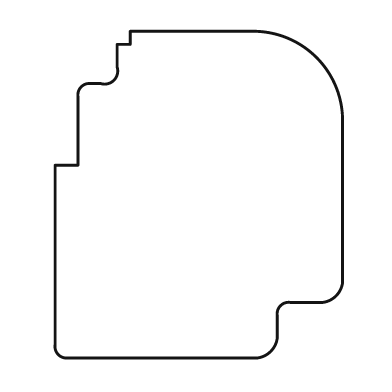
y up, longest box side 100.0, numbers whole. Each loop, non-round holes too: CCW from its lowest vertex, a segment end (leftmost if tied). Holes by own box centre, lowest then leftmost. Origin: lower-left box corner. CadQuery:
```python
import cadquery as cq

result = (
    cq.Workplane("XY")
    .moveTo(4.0, 0.0)
    .lineTo(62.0, 0.0)
    .threePointArc((66.0, 2.0), (68.0, 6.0))
    .lineTo(68.0, 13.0)
    .threePointArc((69.0, 16.0), (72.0, 17.0))
    .lineTo(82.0, 17.0)
    .threePointArc((86.0, 19.0), (88.0, 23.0))
    .lineTo(88.0, 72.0)
    .threePointArc((80.0, 92.0), (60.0, 100.0))
    .lineTo(23.0, 100.0)
    .lineTo(23.0, 96.0)
    .lineTo(19.0, 96.0)
    .lineTo(19.0, 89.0)
    .threePointArc((18.0, 85.0), (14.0, 84.0))
    .lineTo(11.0, 84.0)
    .threePointArc((8.0, 83.0), (7.0, 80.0))
    .lineTo(7.0, 59.0)
    .lineTo(0.0, 59.0)
    .lineTo(0.0, 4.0)
    .threePointArc((1.0, 1.0), (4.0, 0.0))
    .close()
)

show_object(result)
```